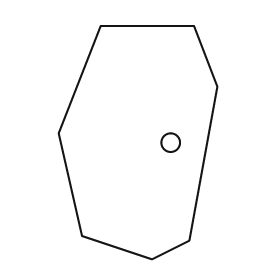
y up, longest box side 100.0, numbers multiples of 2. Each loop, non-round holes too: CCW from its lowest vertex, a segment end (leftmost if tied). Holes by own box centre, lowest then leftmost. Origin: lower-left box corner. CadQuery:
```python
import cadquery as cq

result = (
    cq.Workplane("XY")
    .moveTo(40.0, 0.0)
    .lineTo(56.0, 8.0)
    .lineTo(68.0, 74.0)
    .lineTo(58.0, 100.0)
    .lineTo(18.0, 100.0)
    .lineTo(0.0, 54.0)
    .lineTo(10.0, 10.0)
    .close()
    .moveTo(48.0, 50.0)
    .circle(4.0)
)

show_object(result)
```